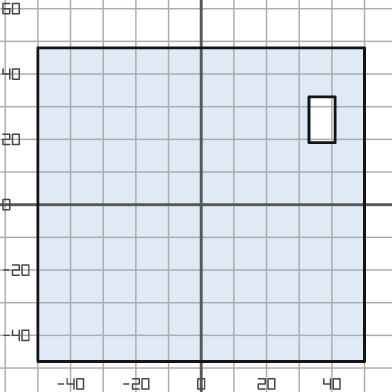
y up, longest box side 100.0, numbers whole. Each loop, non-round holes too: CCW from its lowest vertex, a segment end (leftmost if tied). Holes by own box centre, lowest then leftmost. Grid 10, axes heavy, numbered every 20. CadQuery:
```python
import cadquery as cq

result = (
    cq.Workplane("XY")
    .moveTo(-50.0, -48.0)
    .lineTo(50.0, -48.0)
    .lineTo(50.0, 48.0)
    .lineTo(-50.0, 48.0)
    .close()
    .moveTo(33.0, 19.0)
    .lineTo(41.0, 19.0)
    .lineTo(41.0, 33.0)
    .lineTo(33.0, 33.0)
    .close()
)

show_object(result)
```